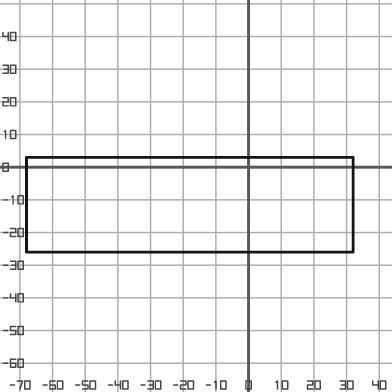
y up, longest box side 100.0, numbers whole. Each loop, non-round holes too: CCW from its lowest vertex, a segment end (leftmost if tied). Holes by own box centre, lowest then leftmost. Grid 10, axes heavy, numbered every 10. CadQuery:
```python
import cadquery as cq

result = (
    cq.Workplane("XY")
    .moveTo(-68.0, -26.0)
    .lineTo(32.0, -26.0)
    .lineTo(32.0, 3.0)
    .lineTo(-68.0, 3.0)
    .close()
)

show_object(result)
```